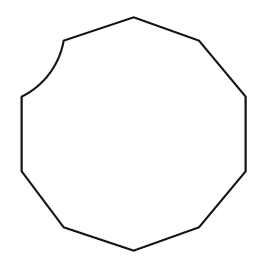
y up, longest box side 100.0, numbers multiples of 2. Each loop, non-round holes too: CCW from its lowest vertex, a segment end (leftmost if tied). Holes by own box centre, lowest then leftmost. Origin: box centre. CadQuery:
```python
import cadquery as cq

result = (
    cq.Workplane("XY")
    .moveTo(0.0, -50.0)
    .lineTo(28.0, -40.0)
    .lineTo(48.0, -16.0)
    .lineTo(48.0, 16.0)
    .lineTo(28.0, 40.0)
    .lineTo(0.0, 50.0)
    .lineTo(-30.0, 40.0)
    .threePointArc((-36.0, 26.0), (-48.0, 16.0))
    .lineTo(-48.0, -16.0)
    .lineTo(-30.0, -40.0)
    .close()
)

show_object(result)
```